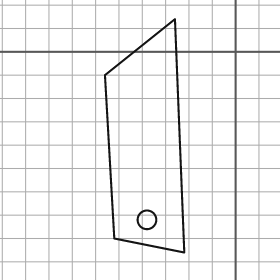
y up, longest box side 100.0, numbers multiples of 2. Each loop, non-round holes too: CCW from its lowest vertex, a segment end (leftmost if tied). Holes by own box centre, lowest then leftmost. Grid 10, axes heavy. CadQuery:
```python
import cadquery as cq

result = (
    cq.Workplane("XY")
    .moveTo(-22.0, -86.0)
    .lineTo(-26.0, 14.0)
    .lineTo(-56.0, -10.0)
    .lineTo(-52.0, -80.0)
    .close()
    .moveTo(-38.0, -72.0)
    .circle(4.0)
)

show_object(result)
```